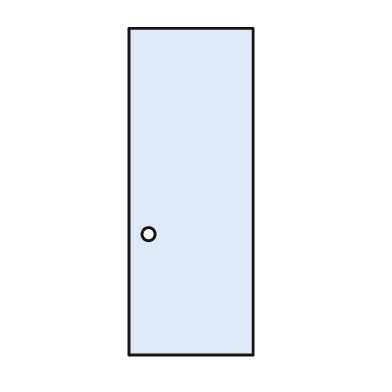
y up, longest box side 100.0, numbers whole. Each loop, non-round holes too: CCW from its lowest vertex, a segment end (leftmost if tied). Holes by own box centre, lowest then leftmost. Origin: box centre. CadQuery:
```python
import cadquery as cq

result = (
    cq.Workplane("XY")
    .moveTo(-19.0, -50.0)
    .lineTo(19.0, -50.0)
    .lineTo(19.0, 50.0)
    .lineTo(-19.0, 50.0)
    .close()
    .moveTo(-13.0, -13.0)
    .circle(2.0)
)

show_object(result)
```